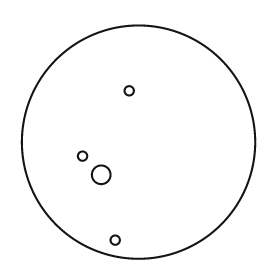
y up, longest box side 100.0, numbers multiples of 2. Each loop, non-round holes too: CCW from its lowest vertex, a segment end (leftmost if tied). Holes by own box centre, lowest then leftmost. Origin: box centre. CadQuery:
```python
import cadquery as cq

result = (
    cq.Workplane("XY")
    .moveTo(0.0, 0.0)
    .circle(50.0)
    .moveTo(-10.0, -42.0)
    .circle(2.0)
    .moveTo(-16.0, -14.0)
    .circle(4.0)
    .moveTo(-24.0, -6.0)
    .circle(2.0)
    .moveTo(-4.0, 22.0)
    .circle(2.0)
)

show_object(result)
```